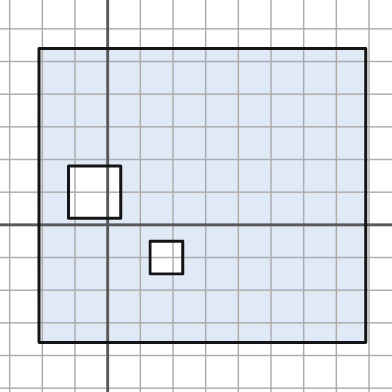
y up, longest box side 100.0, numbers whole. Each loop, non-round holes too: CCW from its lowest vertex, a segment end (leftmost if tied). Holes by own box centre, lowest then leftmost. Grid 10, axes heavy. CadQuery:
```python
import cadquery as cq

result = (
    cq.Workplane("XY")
    .moveTo(-21.0, -36.0)
    .lineTo(79.0, -36.0)
    .lineTo(79.0, 54.0)
    .lineTo(-21.0, 54.0)
    .close()
    .moveTo(13.0, -15.0)
    .lineTo(23.0, -15.0)
    .lineTo(23.0, -5.0)
    .lineTo(13.0, -5.0)
    .close()
    .moveTo(-12.0, 2.0)
    .lineTo(4.0, 2.0)
    .lineTo(4.0, 18.0)
    .lineTo(-12.0, 18.0)
    .close()
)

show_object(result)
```